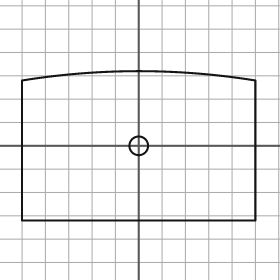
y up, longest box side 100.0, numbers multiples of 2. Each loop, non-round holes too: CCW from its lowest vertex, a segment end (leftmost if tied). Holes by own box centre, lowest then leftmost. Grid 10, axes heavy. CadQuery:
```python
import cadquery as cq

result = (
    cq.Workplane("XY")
    .moveTo(-50.0, -32.0)
    .lineTo(50.0, -32.0)
    .lineTo(50.0, 28.0)
    .threePointArc((0.0, 32.0), (-50.0, 28.0))
    .close()
    .moveTo(0.0, 0.0)
    .circle(4.0)
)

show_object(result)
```